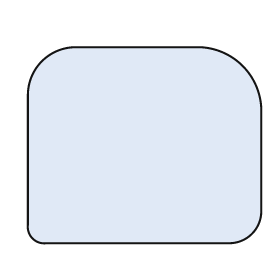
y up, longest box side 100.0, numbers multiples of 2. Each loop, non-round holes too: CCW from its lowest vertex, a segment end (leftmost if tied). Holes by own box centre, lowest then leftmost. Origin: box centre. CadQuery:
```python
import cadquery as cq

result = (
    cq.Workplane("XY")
    .moveTo(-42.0, -42.0)
    .lineTo(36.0, -42.0)
    .threePointArc((46.0, -38.0), (50.0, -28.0))
    .lineTo(50.0, 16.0)
    .threePointArc((42.0, 34.0), (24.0, 42.0))
    .lineTo(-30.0, 42.0)
    .threePointArc((-44.0, 36.0), (-50.0, 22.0))
    .lineTo(-50.0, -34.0)
    .threePointArc((-48.0, -40.0), (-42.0, -42.0))
    .close()
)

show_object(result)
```